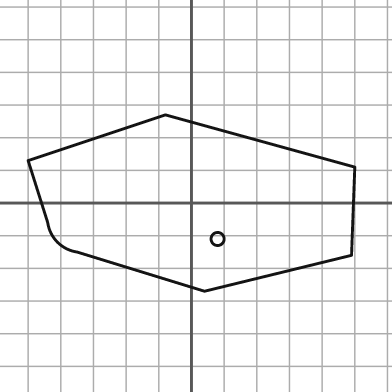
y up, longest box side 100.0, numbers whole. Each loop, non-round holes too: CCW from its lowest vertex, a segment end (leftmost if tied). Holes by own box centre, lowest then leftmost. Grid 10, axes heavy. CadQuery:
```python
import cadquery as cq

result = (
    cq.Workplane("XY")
    .moveTo(4.0, -27.0)
    .lineTo(49.0, -16.0)
    .lineTo(50.0, 11.0)
    .lineTo(-8.0, 27.0)
    .lineTo(-50.0, 13.0)
    .lineTo(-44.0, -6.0)
    .threePointArc((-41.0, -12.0), (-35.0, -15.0))
    .close()
    .moveTo(8.0, -11.0)
    .circle(2.0)
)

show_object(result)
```